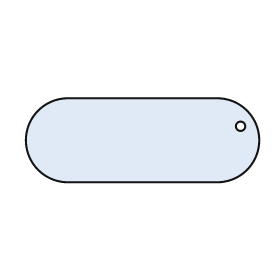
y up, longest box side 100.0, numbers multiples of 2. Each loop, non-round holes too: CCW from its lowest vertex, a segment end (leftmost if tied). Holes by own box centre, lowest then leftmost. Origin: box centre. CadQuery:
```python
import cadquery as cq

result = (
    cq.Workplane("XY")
    .moveTo(-32.0, -18.0)
    .lineTo(32.0, -18.0)
    .threePointArc((50.0, 0.0), (32.0, 18.0))
    .lineTo(-32.0, 18.0)
    .threePointArc((-50.0, 0.0), (-32.0, -18.0))
    .close()
    .moveTo(42.0, 6.0)
    .circle(2.0)
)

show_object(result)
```